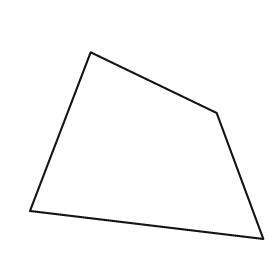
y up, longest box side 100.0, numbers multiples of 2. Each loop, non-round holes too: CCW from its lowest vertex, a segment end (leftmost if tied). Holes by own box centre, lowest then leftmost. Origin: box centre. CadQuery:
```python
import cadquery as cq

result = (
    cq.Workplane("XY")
    .moveTo(50.0, -40.0)
    .lineTo(30.0, 14.0)
    .lineTo(-24.0, 40.0)
    .lineTo(-50.0, -28.0)
    .close()
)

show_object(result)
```